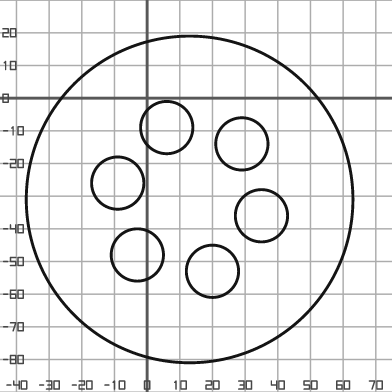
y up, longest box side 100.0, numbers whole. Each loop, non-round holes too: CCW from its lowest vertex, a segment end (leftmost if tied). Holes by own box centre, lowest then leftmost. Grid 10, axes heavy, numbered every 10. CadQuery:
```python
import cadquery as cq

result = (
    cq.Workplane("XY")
    .moveTo(13.0, -31.0)
    .circle(50.0)
    .moveTo(20.0, -53.0)
    .circle(8.0)
    .moveTo(-3.0, -48.0)
    .circle(8.0)
    .moveTo(35.0, -36.0)
    .circle(8.0)
    .moveTo(-9.0, -26.0)
    .circle(8.0)
    .moveTo(29.0, -14.0)
    .circle(8.0)
    .moveTo(6.0, -9.0)
    .circle(8.0)
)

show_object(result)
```